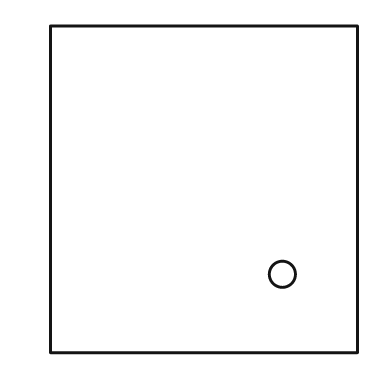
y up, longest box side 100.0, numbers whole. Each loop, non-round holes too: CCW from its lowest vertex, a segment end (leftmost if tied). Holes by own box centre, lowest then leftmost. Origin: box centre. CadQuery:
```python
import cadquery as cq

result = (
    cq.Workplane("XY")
    .moveTo(-47.0, -50.0)
    .lineTo(47.0, -50.0)
    .lineTo(47.0, 50.0)
    .lineTo(-47.0, 50.0)
    .close()
    .moveTo(24.0, -26.0)
    .circle(4.0)
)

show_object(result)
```